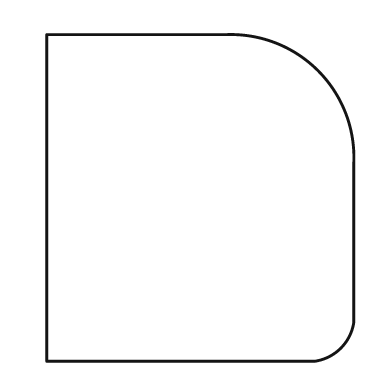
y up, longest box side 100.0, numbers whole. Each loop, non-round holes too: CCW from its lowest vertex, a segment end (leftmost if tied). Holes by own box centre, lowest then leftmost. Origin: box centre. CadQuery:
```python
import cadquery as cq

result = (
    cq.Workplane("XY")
    .moveTo(-47.0, -50.0)
    .lineTo(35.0, -50.0)
    .threePointArc((43.0, -46.0), (47.0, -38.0))
    .lineTo(47.0, 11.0)
    .threePointArc((36.0, 39.0), (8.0, 50.0))
    .lineTo(-47.0, 50.0)
    .close()
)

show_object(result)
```